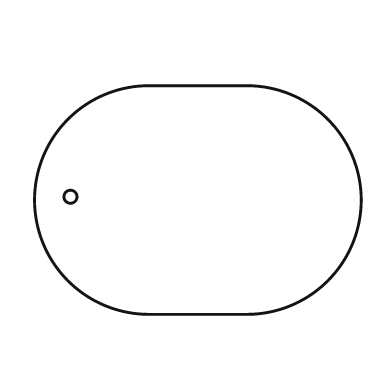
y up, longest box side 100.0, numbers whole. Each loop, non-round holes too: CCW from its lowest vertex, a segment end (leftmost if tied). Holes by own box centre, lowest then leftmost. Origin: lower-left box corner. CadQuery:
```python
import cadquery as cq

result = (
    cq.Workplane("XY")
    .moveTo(35.0, 0.0)
    .lineTo(65.0, 0.0)
    .threePointArc((100.0, 35.0), (65.0, 70.0))
    .lineTo(35.0, 70.0)
    .threePointArc((0.0, 35.0), (35.0, 0.0))
    .close()
    .moveTo(11.0, 36.0)
    .circle(2.0)
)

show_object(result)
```